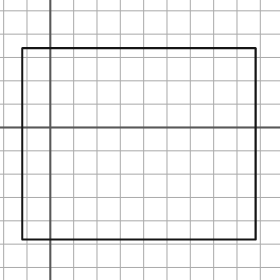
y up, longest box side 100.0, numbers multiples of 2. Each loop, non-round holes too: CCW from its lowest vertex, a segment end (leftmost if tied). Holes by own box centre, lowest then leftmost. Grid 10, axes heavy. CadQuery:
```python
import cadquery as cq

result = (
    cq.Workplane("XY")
    .moveTo(-12.0, -48.0)
    .lineTo(88.0, -48.0)
    .lineTo(88.0, 34.0)
    .lineTo(-12.0, 34.0)
    .close()
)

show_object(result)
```